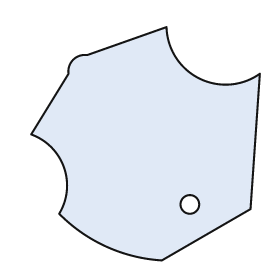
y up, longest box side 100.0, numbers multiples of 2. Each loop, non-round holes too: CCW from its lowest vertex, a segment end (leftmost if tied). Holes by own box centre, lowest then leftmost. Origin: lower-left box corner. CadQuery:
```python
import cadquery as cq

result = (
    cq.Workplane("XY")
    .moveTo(56.0, 0.0)
    .lineTo(94.0, 22.0)
    .lineTo(98.0, 80.0)
    .threePointArc((72.0, 78.0), (58.0, 100.0))
    .lineTo(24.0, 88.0)
    .threePointArc((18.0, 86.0), (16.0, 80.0))
    .lineTo(0.0, 54.0)
    .threePointArc((14.0, 40.0), (12.0, 20.0))
    .threePointArc((32.0, 6.0), (56.0, 0.0))
    .close()
    .moveTo(68.0, 24.0)
    .circle(4.0)
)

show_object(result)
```